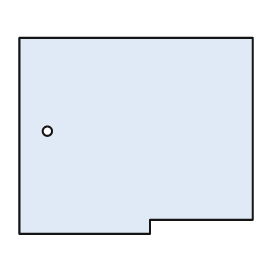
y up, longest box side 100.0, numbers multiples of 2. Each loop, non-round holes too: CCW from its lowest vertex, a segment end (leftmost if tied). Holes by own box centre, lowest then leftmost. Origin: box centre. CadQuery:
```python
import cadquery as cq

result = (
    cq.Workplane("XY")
    .moveTo(-50.0, -42.0)
    .lineTo(6.0, -42.0)
    .lineTo(6.0, -36.0)
    .lineTo(50.0, -36.0)
    .lineTo(50.0, 42.0)
    .lineTo(-50.0, 42.0)
    .close()
    .moveTo(-38.0, 2.0)
    .circle(2.0)
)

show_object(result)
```